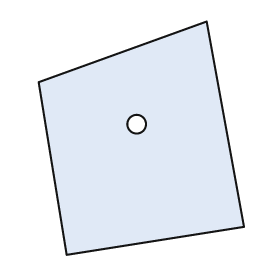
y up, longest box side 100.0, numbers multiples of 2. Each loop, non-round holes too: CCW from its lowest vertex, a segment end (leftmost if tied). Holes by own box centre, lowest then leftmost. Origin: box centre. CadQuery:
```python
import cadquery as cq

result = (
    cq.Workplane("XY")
    .moveTo(-32.0, -50.0)
    .lineTo(44.0, -38.0)
    .lineTo(28.0, 50.0)
    .lineTo(-44.0, 24.0)
    .close()
    .moveTo(-2.0, 6.0)
    .circle(4.0)
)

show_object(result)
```